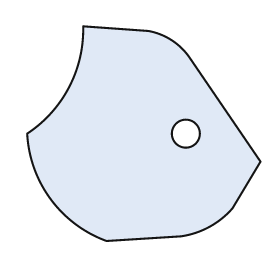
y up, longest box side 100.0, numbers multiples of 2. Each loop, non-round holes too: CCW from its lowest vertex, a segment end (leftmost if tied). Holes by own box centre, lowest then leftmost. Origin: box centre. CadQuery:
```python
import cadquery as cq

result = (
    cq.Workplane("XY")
    .moveTo(-16.0, -46.0)
    .lineTo(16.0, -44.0)
    .threePointArc((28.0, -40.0), (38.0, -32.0))
    .lineTo(50.0, -12.0)
    .lineTo(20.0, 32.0)
    .threePointArc((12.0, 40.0), (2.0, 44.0))
    .lineTo(-26.0, 46.0)
    .threePointArc((-32.0, 20.0), (-50.0, 0.0))
    .threePointArc((-40.0, -28.0), (-16.0, -46.0))
    .close()
    .moveTo(18.0, 0.0)
    .circle(6.0)
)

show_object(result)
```